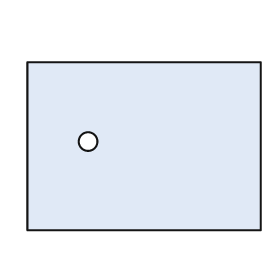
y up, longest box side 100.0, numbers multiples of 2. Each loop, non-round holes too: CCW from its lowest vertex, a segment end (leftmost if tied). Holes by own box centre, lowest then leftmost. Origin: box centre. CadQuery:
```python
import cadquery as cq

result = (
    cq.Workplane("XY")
    .moveTo(-50.0, -36.0)
    .lineTo(50.0, -36.0)
    .lineTo(50.0, 36.0)
    .lineTo(-50.0, 36.0)
    .close()
    .moveTo(-24.0, 2.0)
    .circle(4.0)
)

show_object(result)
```